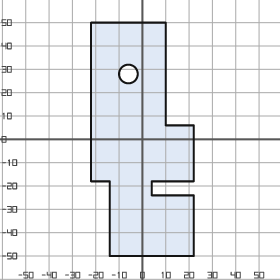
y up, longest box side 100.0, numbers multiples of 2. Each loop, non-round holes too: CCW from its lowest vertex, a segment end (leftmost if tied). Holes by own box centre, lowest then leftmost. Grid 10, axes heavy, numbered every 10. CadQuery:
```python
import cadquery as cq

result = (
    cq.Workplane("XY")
    .moveTo(-14.0, -50.0)
    .lineTo(22.0, -50.0)
    .lineTo(22.0, -24.0)
    .lineTo(4.0, -24.0)
    .lineTo(4.0, -18.0)
    .lineTo(22.0, -18.0)
    .lineTo(22.0, 6.0)
    .lineTo(10.0, 6.0)
    .lineTo(10.0, 50.0)
    .lineTo(-22.0, 50.0)
    .lineTo(-22.0, -18.0)
    .lineTo(-14.0, -18.0)
    .close()
    .moveTo(-6.0, 28.0)
    .circle(4.0)
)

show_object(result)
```